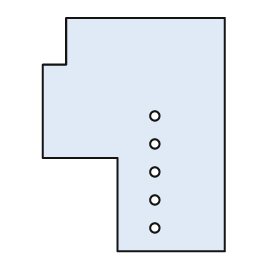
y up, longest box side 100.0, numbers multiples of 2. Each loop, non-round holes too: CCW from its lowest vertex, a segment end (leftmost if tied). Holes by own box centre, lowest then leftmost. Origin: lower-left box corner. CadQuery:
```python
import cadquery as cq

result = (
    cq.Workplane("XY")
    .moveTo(32.0, 0.0)
    .lineTo(78.0, 0.0)
    .lineTo(78.0, 100.0)
    .lineTo(10.0, 100.0)
    .lineTo(10.0, 80.0)
    .lineTo(0.0, 80.0)
    .lineTo(0.0, 40.0)
    .lineTo(32.0, 40.0)
    .close()
    .moveTo(48.0, 10.0)
    .circle(2.0)
    .moveTo(48.0, 22.0)
    .circle(2.0)
    .moveTo(48.0, 34.0)
    .circle(2.0)
    .moveTo(48.0, 46.0)
    .circle(2.0)
    .moveTo(48.0, 58.0)
    .circle(2.0)
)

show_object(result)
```